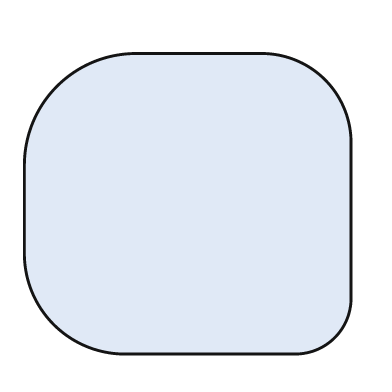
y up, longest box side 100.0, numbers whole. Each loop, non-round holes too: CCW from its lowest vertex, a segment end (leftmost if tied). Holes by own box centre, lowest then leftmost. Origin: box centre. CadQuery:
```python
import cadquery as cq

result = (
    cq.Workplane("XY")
    .moveTo(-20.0, -46.0)
    .lineTo(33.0, -46.0)
    .threePointArc((45.0, -41.0), (50.0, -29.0))
    .lineTo(50.0, 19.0)
    .threePointArc((42.0, 38.0), (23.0, 46.0))
    .lineTo(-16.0, 46.0)
    .threePointArc((-40.0, 36.0), (-50.0, 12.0))
    .lineTo(-50.0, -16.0)
    .threePointArc((-41.0, -37.0), (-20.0, -46.0))
    .close()
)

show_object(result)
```